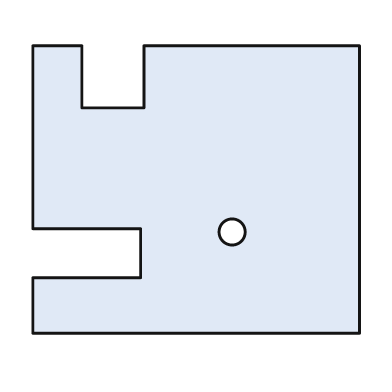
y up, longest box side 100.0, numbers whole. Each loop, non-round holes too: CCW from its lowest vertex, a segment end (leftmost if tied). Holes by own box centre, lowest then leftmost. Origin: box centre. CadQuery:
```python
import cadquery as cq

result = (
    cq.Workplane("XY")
    .moveTo(-50.0, -44.0)
    .lineTo(50.0, -44.0)
    .lineTo(50.0, 44.0)
    .lineTo(-16.0, 44.0)
    .lineTo(-16.0, 25.0)
    .lineTo(-35.0, 25.0)
    .lineTo(-35.0, 44.0)
    .lineTo(-50.0, 44.0)
    .lineTo(-50.0, -12.0)
    .lineTo(-17.0, -12.0)
    .lineTo(-17.0, -27.0)
    .lineTo(-50.0, -27.0)
    .close()
    .moveTo(11.0, -13.0)
    .circle(4.0)
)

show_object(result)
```